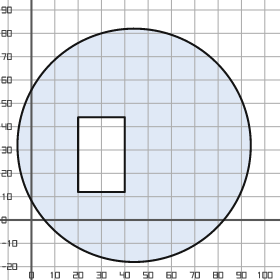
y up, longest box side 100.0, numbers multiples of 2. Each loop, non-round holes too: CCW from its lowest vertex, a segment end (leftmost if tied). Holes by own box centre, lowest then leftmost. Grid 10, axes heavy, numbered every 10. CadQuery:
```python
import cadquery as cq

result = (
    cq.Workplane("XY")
    .moveTo(44.0, 32.0)
    .circle(50.0)
    .moveTo(20.0, 12.0)
    .lineTo(40.0, 12.0)
    .lineTo(40.0, 44.0)
    .lineTo(20.0, 44.0)
    .close()
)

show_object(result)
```